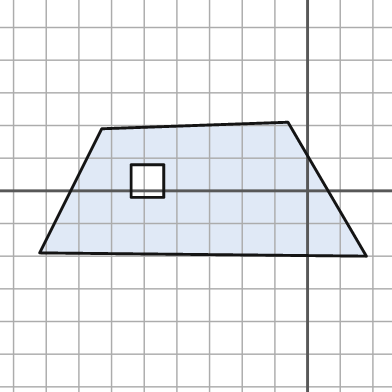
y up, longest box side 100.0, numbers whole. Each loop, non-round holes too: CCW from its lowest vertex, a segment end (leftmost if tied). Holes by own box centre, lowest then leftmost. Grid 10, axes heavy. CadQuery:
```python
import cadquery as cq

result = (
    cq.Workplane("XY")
    .moveTo(18.0, -20.0)
    .lineTo(-6.0, 21.0)
    .lineTo(-63.0, 19.0)
    .lineTo(-82.0, -19.0)
    .close()
    .moveTo(-54.0, -2.0)
    .lineTo(-44.0, -2.0)
    .lineTo(-44.0, 8.0)
    .lineTo(-54.0, 8.0)
    .close()
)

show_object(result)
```